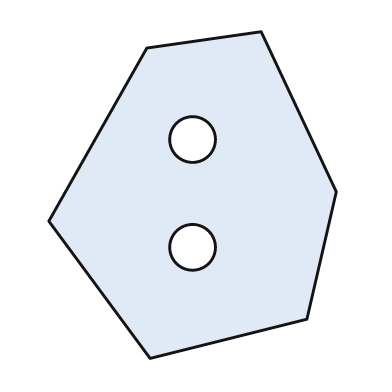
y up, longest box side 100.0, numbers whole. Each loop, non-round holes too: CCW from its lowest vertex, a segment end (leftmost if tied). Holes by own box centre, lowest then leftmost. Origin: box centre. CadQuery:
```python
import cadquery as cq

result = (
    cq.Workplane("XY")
    .moveTo(-13.0, -50.0)
    .lineTo(35.0, -38.0)
    .lineTo(44.0, 1.0)
    .lineTo(21.0, 50.0)
    .lineTo(-14.0, 45.0)
    .lineTo(-44.0, -8.0)
    .close()
    .moveTo(0.0, -16.0)
    .circle(7.0)
    .moveTo(0.0, 17.0)
    .circle(7.0)
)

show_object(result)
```